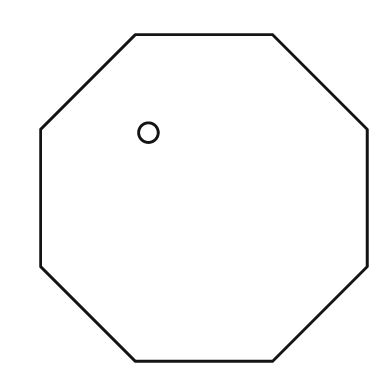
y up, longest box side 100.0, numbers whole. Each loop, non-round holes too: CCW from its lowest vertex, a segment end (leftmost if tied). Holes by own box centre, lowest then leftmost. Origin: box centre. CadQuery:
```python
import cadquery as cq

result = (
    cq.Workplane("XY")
    .moveTo(-21.0, -50.0)
    .lineTo(21.0, -50.0)
    .lineTo(50.0, -21.0)
    .lineTo(50.0, 21.0)
    .lineTo(21.0, 50.0)
    .lineTo(-21.0, 50.0)
    .lineTo(-50.0, 21.0)
    .lineTo(-50.0, -21.0)
    .close()
    .moveTo(-17.0, 20.0)
    .circle(3.0)
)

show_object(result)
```